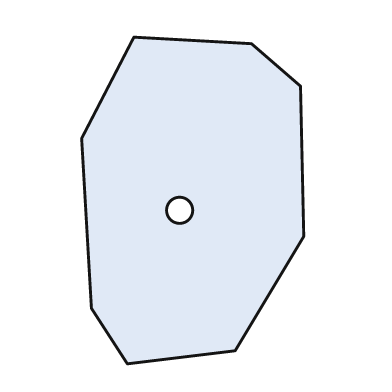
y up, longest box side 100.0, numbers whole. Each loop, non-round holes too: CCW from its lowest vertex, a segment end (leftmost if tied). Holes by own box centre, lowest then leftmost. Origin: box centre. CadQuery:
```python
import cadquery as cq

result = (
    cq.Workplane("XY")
    .moveTo(-20.0, -50.0)
    .lineTo(13.0, -46.0)
    .lineTo(34.0, -11.0)
    .lineTo(33.0, 35.0)
    .lineTo(18.0, 48.0)
    .lineTo(-18.0, 50.0)
    .lineTo(-34.0, 19.0)
    .lineTo(-31.0, -33.0)
    .close()
    .moveTo(-4.0, -3.0)
    .circle(4.0)
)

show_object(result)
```